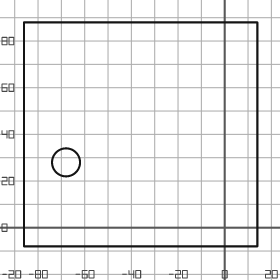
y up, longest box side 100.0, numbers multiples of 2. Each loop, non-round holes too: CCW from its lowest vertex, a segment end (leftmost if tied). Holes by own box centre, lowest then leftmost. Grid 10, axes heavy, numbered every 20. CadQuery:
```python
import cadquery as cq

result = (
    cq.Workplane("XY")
    .moveTo(-86.0, -8.0)
    .lineTo(14.0, -8.0)
    .lineTo(14.0, 88.0)
    .lineTo(-86.0, 88.0)
    .close()
    .moveTo(-68.0, 28.0)
    .circle(6.0)
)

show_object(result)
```